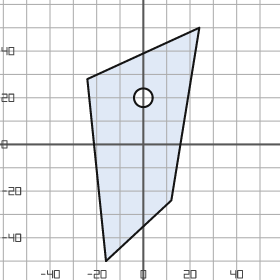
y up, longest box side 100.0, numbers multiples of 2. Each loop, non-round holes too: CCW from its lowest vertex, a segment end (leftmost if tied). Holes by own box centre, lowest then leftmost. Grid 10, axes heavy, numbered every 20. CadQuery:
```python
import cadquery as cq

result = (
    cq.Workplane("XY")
    .moveTo(-16.0, -50.0)
    .lineTo(12.0, -24.0)
    .lineTo(24.0, 50.0)
    .lineTo(-24.0, 28.0)
    .close()
    .moveTo(0.0, 20.0)
    .circle(4.0)
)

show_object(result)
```